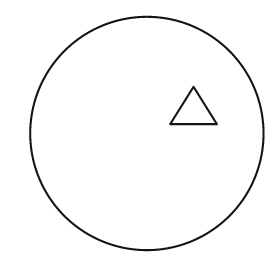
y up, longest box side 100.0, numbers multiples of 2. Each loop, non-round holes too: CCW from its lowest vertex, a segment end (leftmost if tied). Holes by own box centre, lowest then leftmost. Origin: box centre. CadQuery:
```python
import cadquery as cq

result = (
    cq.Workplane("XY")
    .moveTo(0.0, 0.0)
    .circle(50.0)
    .moveTo(10.0, 4.0)
    .lineTo(30.0, 4.0)
    .lineTo(20.0, 20.0)
    .close()
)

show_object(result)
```